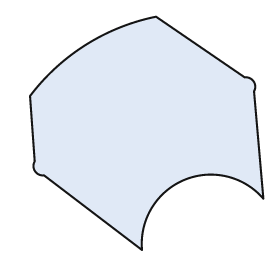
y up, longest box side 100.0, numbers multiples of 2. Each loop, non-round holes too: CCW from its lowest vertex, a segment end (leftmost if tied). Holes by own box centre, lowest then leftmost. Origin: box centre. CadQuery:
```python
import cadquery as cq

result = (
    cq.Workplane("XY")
    .moveTo(-2.0, -50.0)
    .threePointArc((16.0, -20.0), (50.0, -28.0))
    .lineTo(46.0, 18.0)
    .threePointArc((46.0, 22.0), (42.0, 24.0))
    .lineTo(4.0, 50.0)
    .threePointArc((-26.0, 38.0), (-50.0, 16.0))
    .lineTo(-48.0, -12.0)
    .threePointArc((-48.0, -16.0), (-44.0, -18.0))
    .close()
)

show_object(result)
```